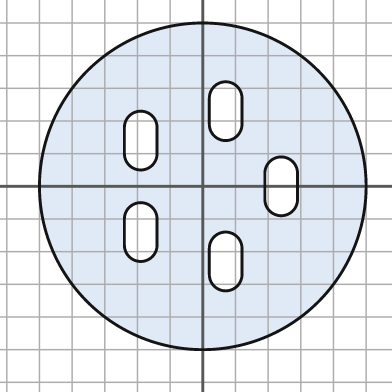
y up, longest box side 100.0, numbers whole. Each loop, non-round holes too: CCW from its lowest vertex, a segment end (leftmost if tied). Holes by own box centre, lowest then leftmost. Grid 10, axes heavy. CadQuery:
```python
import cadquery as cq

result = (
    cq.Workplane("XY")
    .moveTo(0.0, 0.0)
    .circle(50.0)
    .moveTo(2.0, -27.0)
    .threePointArc((7.0, -32.0), (12.0, -27.0))
    .lineTo(12.0, -19.0)
    .threePointArc((7.0, -14.0), (2.0, -19.0))
    .close()
    .moveTo(-24.0, -18.0)
    .threePointArc((-19.0, -23.0), (-14.0, -18.0))
    .lineTo(-14.0, -10.0)
    .threePointArc((-19.0, -5.0), (-24.0, -10.0))
    .close()
    .moveTo(19.0, -4.0)
    .threePointArc((24.0, -9.0), (29.0, -4.0))
    .lineTo(29.0, 4.0)
    .threePointArc((24.0, 9.0), (19.0, 4.0))
    .close()
    .moveTo(-24.0, 10.0)
    .threePointArc((-19.0, 5.0), (-14.0, 10.0))
    .lineTo(-14.0, 18.0)
    .threePointArc((-19.0, 23.0), (-24.0, 18.0))
    .close()
    .moveTo(2.0, 19.0)
    .threePointArc((7.0, 14.0), (12.0, 19.0))
    .lineTo(12.0, 27.0)
    .threePointArc((7.0, 32.0), (2.0, 27.0))
    .close()
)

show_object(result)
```